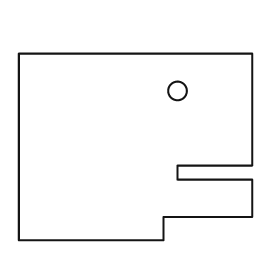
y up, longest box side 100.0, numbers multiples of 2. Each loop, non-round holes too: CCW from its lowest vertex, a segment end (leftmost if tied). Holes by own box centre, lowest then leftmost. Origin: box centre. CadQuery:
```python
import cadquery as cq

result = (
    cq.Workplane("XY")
    .moveTo(-50.0, -40.0)
    .lineTo(12.0, -40.0)
    .lineTo(12.0, -30.0)
    .lineTo(50.0, -30.0)
    .lineTo(50.0, -14.0)
    .lineTo(18.0, -14.0)
    .lineTo(18.0, -8.0)
    .lineTo(50.0, -8.0)
    .lineTo(50.0, 40.0)
    .lineTo(-50.0, 40.0)
    .close()
    .moveTo(18.0, 24.0)
    .circle(4.0)
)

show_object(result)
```